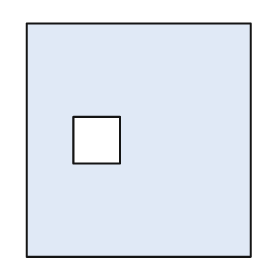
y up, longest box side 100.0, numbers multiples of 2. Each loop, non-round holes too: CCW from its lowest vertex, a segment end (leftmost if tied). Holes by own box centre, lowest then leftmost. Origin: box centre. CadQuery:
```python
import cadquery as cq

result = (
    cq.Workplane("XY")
    .moveTo(-48.0, -50.0)
    .lineTo(48.0, -50.0)
    .lineTo(48.0, 50.0)
    .lineTo(-48.0, 50.0)
    .close()
    .moveTo(-28.0, -10.0)
    .lineTo(-8.0, -10.0)
    .lineTo(-8.0, 10.0)
    .lineTo(-28.0, 10.0)
    .close()
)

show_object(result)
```